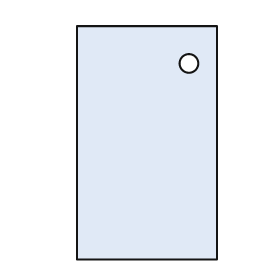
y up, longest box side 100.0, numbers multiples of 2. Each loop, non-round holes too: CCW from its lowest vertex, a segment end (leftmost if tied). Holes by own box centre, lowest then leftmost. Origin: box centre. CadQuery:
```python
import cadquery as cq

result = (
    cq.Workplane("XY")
    .moveTo(-30.0, -50.0)
    .lineTo(30.0, -50.0)
    .lineTo(30.0, 50.0)
    .lineTo(-30.0, 50.0)
    .close()
    .moveTo(18.0, 34.0)
    .circle(4.0)
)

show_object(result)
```